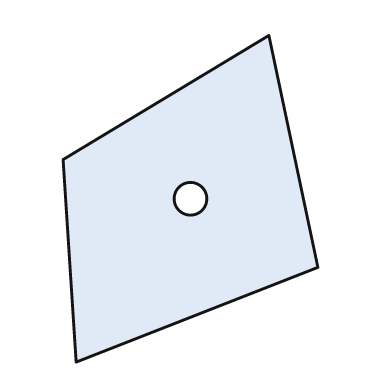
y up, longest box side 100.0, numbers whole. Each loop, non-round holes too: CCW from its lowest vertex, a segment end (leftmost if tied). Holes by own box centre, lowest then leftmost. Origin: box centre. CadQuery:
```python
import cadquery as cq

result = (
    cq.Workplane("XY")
    .moveTo(-35.0, -50.0)
    .lineTo(39.0, -21.0)
    .lineTo(24.0, 50.0)
    .lineTo(-39.0, 12.0)
    .close()
    .moveTo(0.0, 0.0)
    .circle(5.0)
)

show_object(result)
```